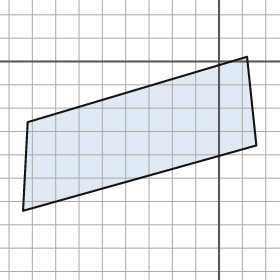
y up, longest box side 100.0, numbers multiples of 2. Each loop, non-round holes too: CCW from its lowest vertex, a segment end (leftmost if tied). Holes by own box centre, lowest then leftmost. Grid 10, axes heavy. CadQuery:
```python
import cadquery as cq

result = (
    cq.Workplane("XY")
    .moveTo(-84.0, -64.0)
    .lineTo(16.0, -36.0)
    .lineTo(12.0, 2.0)
    .lineTo(-82.0, -26.0)
    .close()
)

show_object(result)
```